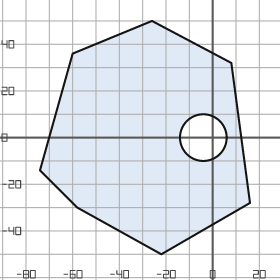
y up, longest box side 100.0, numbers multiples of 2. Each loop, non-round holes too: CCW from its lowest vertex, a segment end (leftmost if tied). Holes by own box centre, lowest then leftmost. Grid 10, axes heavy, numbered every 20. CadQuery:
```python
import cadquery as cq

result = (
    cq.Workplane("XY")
    .moveTo(-22.0, -50.0)
    .lineTo(16.0, -28.0)
    .lineTo(8.0, 32.0)
    .lineTo(-26.0, 50.0)
    .lineTo(-60.0, 36.0)
    .lineTo(-74.0, -14.0)
    .lineTo(-58.0, -30.0)
    .close()
    .moveTo(-4.0, 0.0)
    .circle(10.0)
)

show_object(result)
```